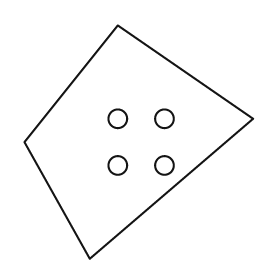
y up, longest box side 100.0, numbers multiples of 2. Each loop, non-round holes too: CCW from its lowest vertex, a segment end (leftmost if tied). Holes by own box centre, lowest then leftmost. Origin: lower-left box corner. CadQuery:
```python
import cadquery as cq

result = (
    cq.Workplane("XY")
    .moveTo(28.0, 0.0)
    .lineTo(98.0, 60.0)
    .lineTo(40.0, 100.0)
    .lineTo(0.0, 50.0)
    .close()
    .moveTo(40.0, 40.0)
    .circle(4.0)
    .moveTo(60.0, 40.0)
    .circle(4.0)
    .moveTo(40.0, 60.0)
    .circle(4.0)
    .moveTo(60.0, 60.0)
    .circle(4.0)
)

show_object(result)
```